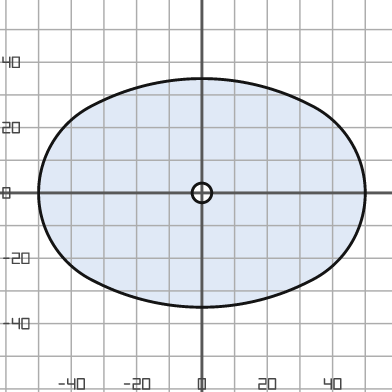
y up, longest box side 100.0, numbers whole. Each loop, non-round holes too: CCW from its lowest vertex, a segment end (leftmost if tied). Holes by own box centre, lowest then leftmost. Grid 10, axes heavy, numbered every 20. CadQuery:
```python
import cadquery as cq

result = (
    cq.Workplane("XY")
    .moveTo(-33.0, -27.0)
    .threePointArc((0.0, -35.0), (33.0, -27.0))
    .threePointArc((50.0, 0.0), (33.0, 27.0))
    .threePointArc((0.0, 35.0), (-33.0, 27.0))
    .threePointArc((-50.0, 0.0), (-33.0, -27.0))
    .close()
    .moveTo(0.0, 0.0)
    .circle(3.0)
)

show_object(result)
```